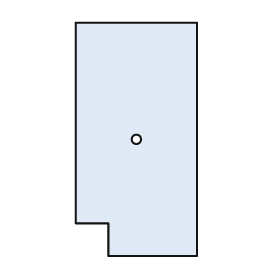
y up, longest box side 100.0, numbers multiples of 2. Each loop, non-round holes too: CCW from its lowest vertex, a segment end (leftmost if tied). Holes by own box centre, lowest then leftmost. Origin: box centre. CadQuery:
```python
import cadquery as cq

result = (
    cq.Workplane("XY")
    .moveTo(-12.0, -50.0)
    .lineTo(26.0, -50.0)
    .lineTo(26.0, 50.0)
    .lineTo(-26.0, 50.0)
    .lineTo(-26.0, -36.0)
    .lineTo(-12.0, -36.0)
    .close()
    .moveTo(0.0, 0.0)
    .circle(2.0)
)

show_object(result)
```